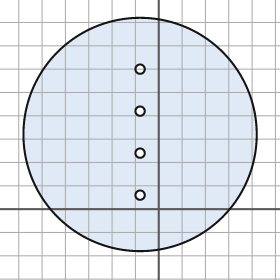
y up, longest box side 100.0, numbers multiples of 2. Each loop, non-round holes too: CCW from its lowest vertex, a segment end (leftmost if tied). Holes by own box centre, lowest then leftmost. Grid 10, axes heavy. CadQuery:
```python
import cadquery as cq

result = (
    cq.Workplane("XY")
    .moveTo(-8.0, 32.0)
    .circle(50.0)
    .moveTo(-8.0, 6.0)
    .circle(2.0)
    .moveTo(-8.0, 24.0)
    .circle(2.0)
    .moveTo(-8.0, 42.0)
    .circle(2.0)
    .moveTo(-8.0, 60.0)
    .circle(2.0)
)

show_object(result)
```